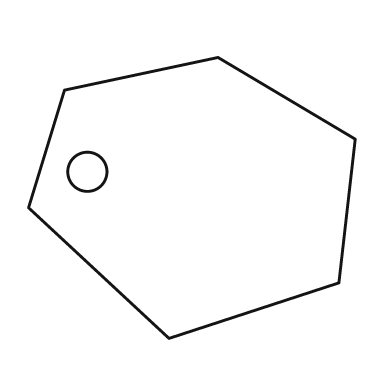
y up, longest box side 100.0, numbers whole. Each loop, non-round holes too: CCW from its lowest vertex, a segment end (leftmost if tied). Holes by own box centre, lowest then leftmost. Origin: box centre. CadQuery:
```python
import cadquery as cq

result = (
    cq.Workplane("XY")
    .moveTo(-7.0, -43.0)
    .lineTo(45.0, -26.0)
    .lineTo(50.0, 18.0)
    .lineTo(8.0, 43.0)
    .lineTo(-39.0, 33.0)
    .lineTo(-50.0, -3.0)
    .close()
    .moveTo(-32.0, 8.0)
    .circle(6.0)
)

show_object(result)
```